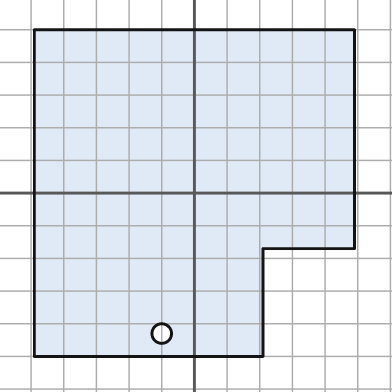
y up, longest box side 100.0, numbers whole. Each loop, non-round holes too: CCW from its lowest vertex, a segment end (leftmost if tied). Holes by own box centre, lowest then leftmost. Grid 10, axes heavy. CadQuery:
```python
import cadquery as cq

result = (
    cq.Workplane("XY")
    .moveTo(-49.0, -50.0)
    .lineTo(21.0, -50.0)
    .lineTo(21.0, -17.0)
    .lineTo(49.0, -17.0)
    .lineTo(49.0, 50.0)
    .lineTo(-49.0, 50.0)
    .close()
    .moveTo(-10.0, -43.0)
    .circle(3.0)
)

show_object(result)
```